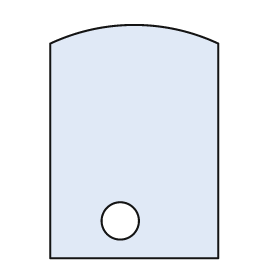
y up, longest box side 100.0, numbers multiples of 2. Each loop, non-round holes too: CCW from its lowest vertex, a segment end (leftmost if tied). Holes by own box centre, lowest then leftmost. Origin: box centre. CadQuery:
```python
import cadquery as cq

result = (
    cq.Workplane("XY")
    .moveTo(-36.0, -50.0)
    .lineTo(36.0, -50.0)
    .lineTo(36.0, 42.0)
    .threePointArc((0.0, 50.0), (-36.0, 42.0))
    .close()
    .moveTo(-6.0, -34.0)
    .circle(8.0)
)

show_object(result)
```